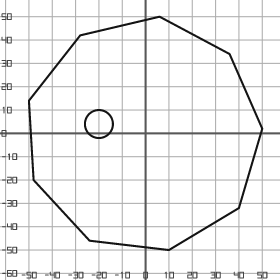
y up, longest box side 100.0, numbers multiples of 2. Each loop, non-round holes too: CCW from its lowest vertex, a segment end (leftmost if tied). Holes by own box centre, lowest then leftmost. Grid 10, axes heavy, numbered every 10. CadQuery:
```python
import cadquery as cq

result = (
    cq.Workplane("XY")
    .moveTo(10.0, -50.0)
    .lineTo(40.0, -32.0)
    .lineTo(50.0, 2.0)
    .lineTo(36.0, 34.0)
    .lineTo(6.0, 50.0)
    .lineTo(-28.0, 42.0)
    .lineTo(-50.0, 14.0)
    .lineTo(-48.0, -20.0)
    .lineTo(-24.0, -46.0)
    .close()
    .moveTo(-20.0, 4.0)
    .circle(6.0)
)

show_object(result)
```